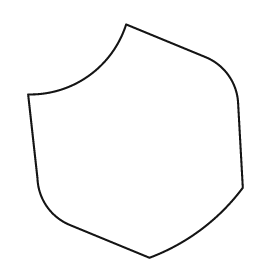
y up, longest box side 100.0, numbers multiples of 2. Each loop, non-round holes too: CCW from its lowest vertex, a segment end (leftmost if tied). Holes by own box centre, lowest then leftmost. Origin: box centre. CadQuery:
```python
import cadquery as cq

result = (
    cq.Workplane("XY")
    .moveTo(6.0, -50.0)
    .threePointArc((28.0, -38.0), (46.0, -20.0))
    .lineTo(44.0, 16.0)
    .threePointArc((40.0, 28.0), (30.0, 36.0))
    .lineTo(-4.0, 50.0)
    .threePointArc((-20.0, 28.0), (-46.0, 20.0))
    .lineTo(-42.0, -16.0)
    .threePointArc((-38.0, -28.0), (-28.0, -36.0))
    .close()
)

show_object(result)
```